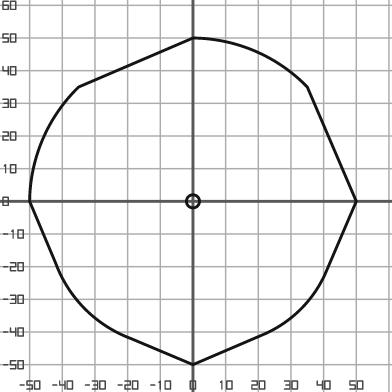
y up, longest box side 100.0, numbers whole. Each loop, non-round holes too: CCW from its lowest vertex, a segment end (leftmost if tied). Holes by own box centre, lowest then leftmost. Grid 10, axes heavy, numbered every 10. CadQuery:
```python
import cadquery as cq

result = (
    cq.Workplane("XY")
    .moveTo(0.0, -50.0)
    .lineTo(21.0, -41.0)
    .threePointArc((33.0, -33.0), (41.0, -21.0))
    .lineTo(50.0, 0.0)
    .lineTo(35.0, 35.0)
    .threePointArc((19.0, 46.0), (0.0, 50.0))
    .lineTo(-35.0, 35.0)
    .threePointArc((-46.0, 19.0), (-50.0, 0.0))
    .lineTo(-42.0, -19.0)
    .threePointArc((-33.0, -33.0), (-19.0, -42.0))
    .close()
    .moveTo(0.0, 0.0)
    .circle(2.0)
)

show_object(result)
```